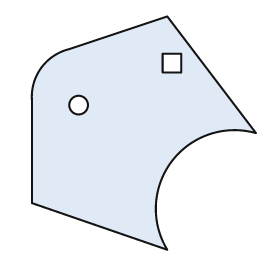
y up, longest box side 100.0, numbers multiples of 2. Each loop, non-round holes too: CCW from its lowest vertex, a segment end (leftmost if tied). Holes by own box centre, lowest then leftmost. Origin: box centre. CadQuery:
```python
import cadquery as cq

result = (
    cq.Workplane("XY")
    .moveTo(10.0, -50.0)
    .threePointArc((12.0, -12.0), (48.0, 0.0))
    .lineTo(10.0, 50.0)
    .lineTo(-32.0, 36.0)
    .threePointArc((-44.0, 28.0), (-48.0, 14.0))
    .lineTo(-48.0, -30.0)
    .close()
    .moveTo(-28.0, 12.0)
    .circle(4.0)
    .moveTo(8.0, 26.0)
    .lineTo(16.0, 26.0)
    .lineTo(16.0, 34.0)
    .lineTo(8.0, 34.0)
    .close()
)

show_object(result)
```